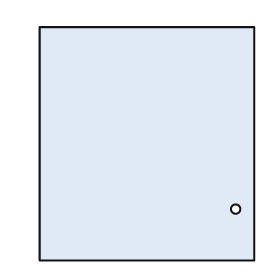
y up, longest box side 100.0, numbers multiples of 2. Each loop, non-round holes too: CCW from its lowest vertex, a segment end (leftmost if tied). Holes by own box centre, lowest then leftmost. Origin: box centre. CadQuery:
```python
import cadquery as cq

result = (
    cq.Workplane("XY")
    .moveTo(-46.0, -50.0)
    .lineTo(46.0, -50.0)
    .lineTo(46.0, 50.0)
    .lineTo(-46.0, 50.0)
    .close()
    .moveTo(38.0, -28.0)
    .circle(2.0)
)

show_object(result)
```